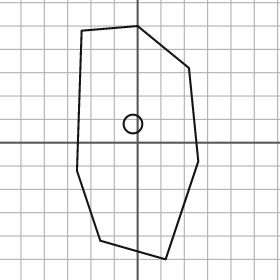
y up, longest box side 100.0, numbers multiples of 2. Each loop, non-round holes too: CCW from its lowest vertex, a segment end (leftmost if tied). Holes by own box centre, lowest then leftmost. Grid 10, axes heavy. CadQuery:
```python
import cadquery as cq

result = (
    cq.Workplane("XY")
    .moveTo(12.0, -50.0)
    .lineTo(26.0, -8.0)
    .lineTo(22.0, 32.0)
    .lineTo(0.0, 50.0)
    .lineTo(-24.0, 48.0)
    .lineTo(-26.0, -12.0)
    .lineTo(-16.0, -42.0)
    .close()
    .moveTo(-2.0, 8.0)
    .circle(4.0)
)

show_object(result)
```